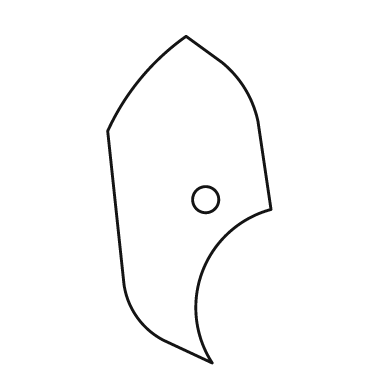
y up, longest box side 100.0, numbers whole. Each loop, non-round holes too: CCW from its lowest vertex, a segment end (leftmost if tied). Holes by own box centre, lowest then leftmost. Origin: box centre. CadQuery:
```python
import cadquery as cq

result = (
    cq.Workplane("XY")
    .moveTo(7.0, -50.0)
    .threePointArc((4.0, -22.0), (25.0, -3.0))
    .lineTo(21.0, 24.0)
    .threePointArc((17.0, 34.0), (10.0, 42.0))
    .lineTo(-1.0, 50.0)
    .threePointArc((-15.0, 37.0), (-25.0, 21.0))
    .lineTo(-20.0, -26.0)
    .threePointArc((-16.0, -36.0), (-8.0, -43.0))
    .close()
    .moveTo(5.0, 0.0)
    .circle(4.0)
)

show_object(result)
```